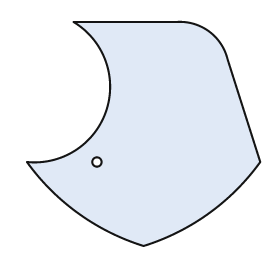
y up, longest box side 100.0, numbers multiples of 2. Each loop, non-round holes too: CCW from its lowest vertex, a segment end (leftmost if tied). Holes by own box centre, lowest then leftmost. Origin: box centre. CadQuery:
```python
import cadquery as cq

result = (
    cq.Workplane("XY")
    .moveTo(0.0, -48.0)
    .threePointArc((28.0, -34.0), (50.0, -12.0))
    .lineTo(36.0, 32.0)
    .threePointArc((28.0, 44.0), (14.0, 48.0))
    .lineTo(-30.0, 48.0)
    .threePointArc((-16.0, 10.0), (-50.0, -12.0))
    .threePointArc((-28.0, -34.0), (0.0, -48.0))
    .close()
    .moveTo(-20.0, -12.0)
    .circle(2.0)
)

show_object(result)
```